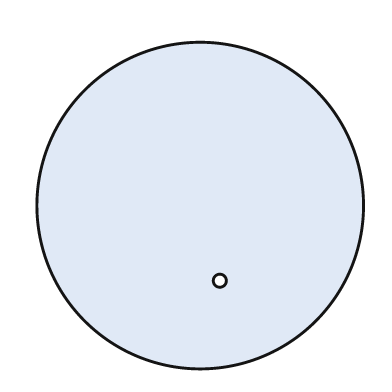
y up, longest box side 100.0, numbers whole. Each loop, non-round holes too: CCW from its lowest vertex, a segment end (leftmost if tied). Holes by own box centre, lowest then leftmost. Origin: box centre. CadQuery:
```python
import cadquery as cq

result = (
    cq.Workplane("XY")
    .moveTo(0.0, 0.0)
    .circle(50.0)
    .moveTo(6.0, -23.0)
    .circle(2.0)
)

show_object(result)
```